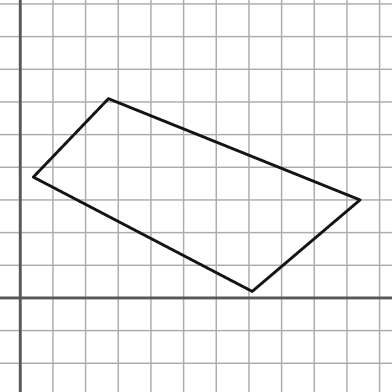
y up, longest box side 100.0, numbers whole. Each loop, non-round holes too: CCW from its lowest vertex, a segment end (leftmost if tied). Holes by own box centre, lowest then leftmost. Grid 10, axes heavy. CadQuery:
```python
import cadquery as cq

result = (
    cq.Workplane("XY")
    .moveTo(71.0, 2.0)
    .lineTo(104.0, 30.0)
    .lineTo(27.0, 61.0)
    .lineTo(4.0, 37.0)
    .close()
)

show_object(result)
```